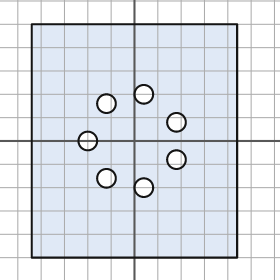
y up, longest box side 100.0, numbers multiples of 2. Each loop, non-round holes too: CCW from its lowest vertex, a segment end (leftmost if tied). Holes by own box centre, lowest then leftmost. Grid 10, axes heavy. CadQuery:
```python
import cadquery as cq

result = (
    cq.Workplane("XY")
    .moveTo(-44.0, -50.0)
    .lineTo(44.0, -50.0)
    .lineTo(44.0, 50.0)
    .lineTo(-44.0, 50.0)
    .close()
    .moveTo(4.0, -20.0)
    .circle(4.0)
    .moveTo(-12.0, -16.0)
    .circle(4.0)
    .moveTo(18.0, -8.0)
    .circle(4.0)
    .moveTo(-20.0, 0.0)
    .circle(4.0)
    .moveTo(18.0, 8.0)
    .circle(4.0)
    .moveTo(-12.0, 16.0)
    .circle(4.0)
    .moveTo(4.0, 20.0)
    .circle(4.0)
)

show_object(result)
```